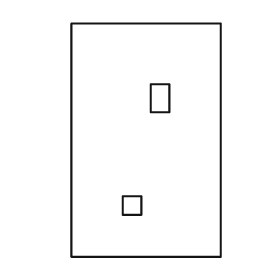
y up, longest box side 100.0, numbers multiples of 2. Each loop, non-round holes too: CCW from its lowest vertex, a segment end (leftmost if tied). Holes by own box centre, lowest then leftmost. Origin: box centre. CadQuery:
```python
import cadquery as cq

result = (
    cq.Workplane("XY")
    .moveTo(-32.0, -50.0)
    .lineTo(32.0, -50.0)
    .lineTo(32.0, 50.0)
    .lineTo(-32.0, 50.0)
    .close()
    .moveTo(-10.0, -32.0)
    .lineTo(-2.0, -32.0)
    .lineTo(-2.0, -24.0)
    .lineTo(-10.0, -24.0)
    .close()
    .moveTo(2.0, 12.0)
    .lineTo(10.0, 12.0)
    .lineTo(10.0, 24.0)
    .lineTo(2.0, 24.0)
    .close()
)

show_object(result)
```